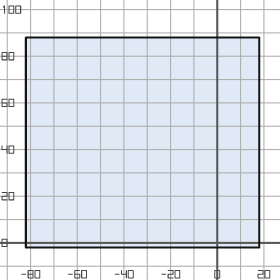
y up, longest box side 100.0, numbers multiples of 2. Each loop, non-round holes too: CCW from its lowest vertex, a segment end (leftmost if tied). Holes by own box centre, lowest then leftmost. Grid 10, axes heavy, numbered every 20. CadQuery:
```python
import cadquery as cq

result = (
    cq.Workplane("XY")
    .moveTo(-82.0, -2.0)
    .lineTo(18.0, -2.0)
    .lineTo(18.0, 88.0)
    .lineTo(-82.0, 88.0)
    .close()
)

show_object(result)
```